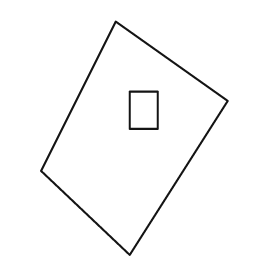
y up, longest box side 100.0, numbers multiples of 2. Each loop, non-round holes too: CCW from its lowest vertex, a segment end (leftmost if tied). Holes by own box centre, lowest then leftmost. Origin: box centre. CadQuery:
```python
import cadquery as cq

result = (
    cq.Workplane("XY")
    .moveTo(-2.0, -50.0)
    .lineTo(40.0, 16.0)
    .lineTo(-8.0, 50.0)
    .lineTo(-40.0, -14.0)
    .close()
    .moveTo(-2.0, 4.0)
    .lineTo(10.0, 4.0)
    .lineTo(10.0, 20.0)
    .lineTo(-2.0, 20.0)
    .close()
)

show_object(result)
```